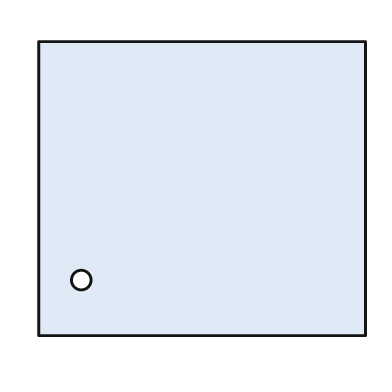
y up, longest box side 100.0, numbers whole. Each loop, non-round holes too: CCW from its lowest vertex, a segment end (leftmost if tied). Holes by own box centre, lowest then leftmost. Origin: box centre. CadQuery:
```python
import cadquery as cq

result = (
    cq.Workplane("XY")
    .moveTo(-50.0, -45.0)
    .lineTo(50.0, -45.0)
    .lineTo(50.0, 45.0)
    .lineTo(-50.0, 45.0)
    .close()
    .moveTo(-37.0, -28.0)
    .circle(3.0)
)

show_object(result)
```